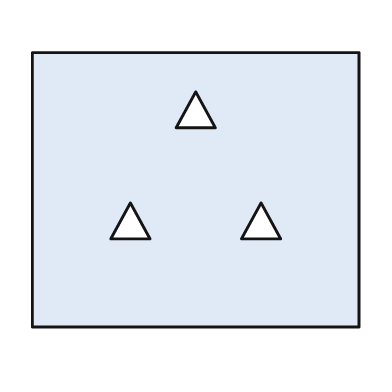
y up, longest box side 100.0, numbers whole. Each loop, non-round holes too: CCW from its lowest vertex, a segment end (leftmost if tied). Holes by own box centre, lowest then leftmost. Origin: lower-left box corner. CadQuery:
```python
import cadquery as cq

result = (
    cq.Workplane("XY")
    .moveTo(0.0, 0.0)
    .lineTo(100.0, 0.0)
    .lineTo(100.0, 84.0)
    .lineTo(0.0, 84.0)
    .close()
    .moveTo(24.0, 27.0)
    .lineTo(36.0, 27.0)
    .lineTo(30.0, 38.0)
    .close()
    .moveTo(64.0, 27.0)
    .lineTo(76.0, 27.0)
    .lineTo(70.0, 38.0)
    .close()
    .moveTo(44.0, 61.0)
    .lineTo(56.0, 61.0)
    .lineTo(50.0, 72.0)
    .close()
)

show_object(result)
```